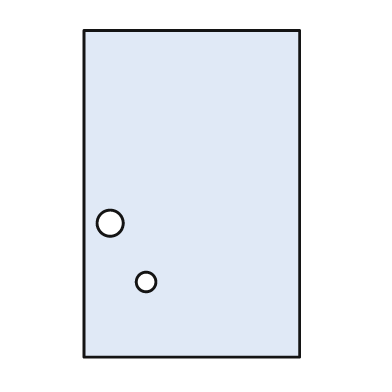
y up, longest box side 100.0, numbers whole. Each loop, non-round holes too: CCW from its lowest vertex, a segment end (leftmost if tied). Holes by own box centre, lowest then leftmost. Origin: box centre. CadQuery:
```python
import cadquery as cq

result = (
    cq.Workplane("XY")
    .moveTo(-33.0, -50.0)
    .lineTo(33.0, -50.0)
    .lineTo(33.0, 50.0)
    .lineTo(-33.0, 50.0)
    .close()
    .moveTo(-14.0, -27.0)
    .circle(3.0)
    .moveTo(-25.0, -9.0)
    .circle(4.0)
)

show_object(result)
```